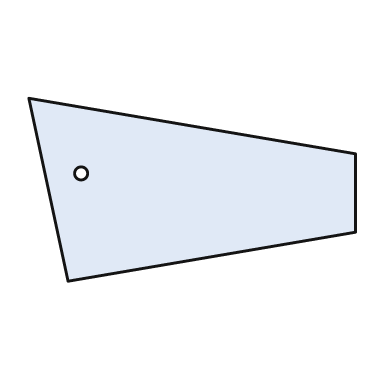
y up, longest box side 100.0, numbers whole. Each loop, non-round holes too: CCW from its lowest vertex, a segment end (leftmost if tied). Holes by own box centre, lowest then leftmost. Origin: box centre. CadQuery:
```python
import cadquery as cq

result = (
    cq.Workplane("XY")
    .moveTo(-38.0, -28.0)
    .lineTo(50.0, -13.0)
    .lineTo(50.0, 11.0)
    .lineTo(-50.0, 28.0)
    .close()
    .moveTo(-34.0, 5.0)
    .circle(2.0)
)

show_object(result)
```